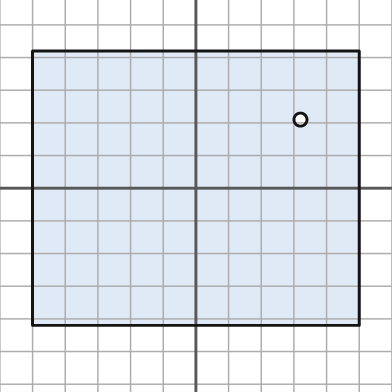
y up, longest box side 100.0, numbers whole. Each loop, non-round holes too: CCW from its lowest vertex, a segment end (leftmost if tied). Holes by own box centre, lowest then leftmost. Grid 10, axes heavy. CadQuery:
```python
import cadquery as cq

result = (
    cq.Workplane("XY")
    .moveTo(-50.0, -42.0)
    .lineTo(50.0, -42.0)
    .lineTo(50.0, 42.0)
    .lineTo(-50.0, 42.0)
    .close()
    .moveTo(32.0, 21.0)
    .circle(2.0)
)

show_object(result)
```